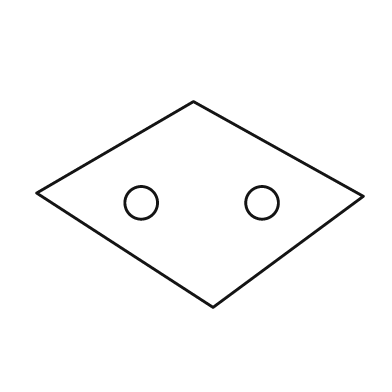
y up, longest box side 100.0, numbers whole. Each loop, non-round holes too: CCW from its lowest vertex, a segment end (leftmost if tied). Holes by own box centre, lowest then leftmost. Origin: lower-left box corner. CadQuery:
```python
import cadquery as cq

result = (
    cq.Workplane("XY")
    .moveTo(54.0, 0.0)
    .lineTo(100.0, 34.0)
    .lineTo(48.0, 63.0)
    .lineTo(0.0, 35.0)
    .close()
    .moveTo(32.0, 32.0)
    .circle(5.0)
    .moveTo(69.0, 32.0)
    .circle(5.0)
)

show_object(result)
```